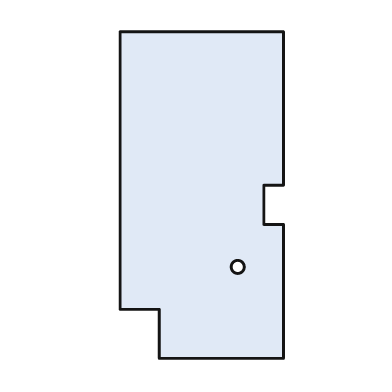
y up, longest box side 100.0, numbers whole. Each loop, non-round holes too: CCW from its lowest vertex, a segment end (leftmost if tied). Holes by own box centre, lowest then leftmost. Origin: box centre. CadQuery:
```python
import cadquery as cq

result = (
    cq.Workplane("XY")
    .moveTo(-13.0, -50.0)
    .lineTo(25.0, -50.0)
    .lineTo(25.0, -9.0)
    .lineTo(19.0, -9.0)
    .lineTo(19.0, 3.0)
    .lineTo(25.0, 3.0)
    .lineTo(25.0, 50.0)
    .lineTo(-25.0, 50.0)
    .lineTo(-25.0, -35.0)
    .lineTo(-13.0, -35.0)
    .close()
    .moveTo(11.0, -22.0)
    .circle(2.0)
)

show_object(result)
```